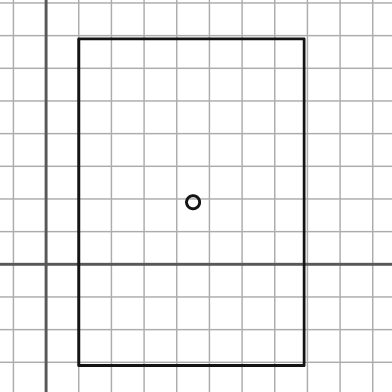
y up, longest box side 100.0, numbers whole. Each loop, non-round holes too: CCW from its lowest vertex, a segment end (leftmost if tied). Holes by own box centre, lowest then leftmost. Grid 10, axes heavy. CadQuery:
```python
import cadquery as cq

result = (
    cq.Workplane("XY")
    .moveTo(10.0, -31.0)
    .lineTo(79.0, -31.0)
    .lineTo(79.0, 69.0)
    .lineTo(10.0, 69.0)
    .close()
    .moveTo(45.0, 19.0)
    .circle(2.0)
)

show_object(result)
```